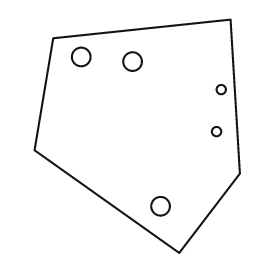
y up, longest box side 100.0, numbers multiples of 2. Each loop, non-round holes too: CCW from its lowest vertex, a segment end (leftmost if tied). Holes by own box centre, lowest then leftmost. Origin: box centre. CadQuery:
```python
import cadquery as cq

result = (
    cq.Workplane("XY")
    .moveTo(18.0, -50.0)
    .lineTo(44.0, -16.0)
    .lineTo(40.0, 50.0)
    .lineTo(-36.0, 42.0)
    .lineTo(-44.0, -6.0)
    .close()
    .moveTo(10.0, -30.0)
    .circle(4.0)
    .moveTo(34.0, 2.0)
    .circle(2.0)
    .moveTo(36.0, 20.0)
    .circle(2.0)
    .moveTo(-2.0, 32.0)
    .circle(4.0)
    .moveTo(-24.0, 34.0)
    .circle(4.0)
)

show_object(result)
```